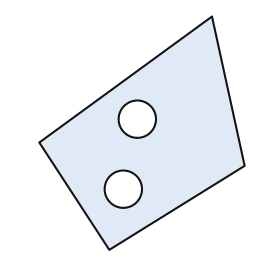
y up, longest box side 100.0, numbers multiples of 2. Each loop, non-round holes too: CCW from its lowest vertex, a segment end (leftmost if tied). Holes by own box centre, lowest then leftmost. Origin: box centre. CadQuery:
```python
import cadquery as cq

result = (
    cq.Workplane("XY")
    .moveTo(-14.0, -50.0)
    .lineTo(44.0, -14.0)
    .lineTo(30.0, 50.0)
    .lineTo(-44.0, -4.0)
    .close()
    .moveTo(-8.0, -24.0)
    .circle(8.0)
    .moveTo(-2.0, 6.0)
    .circle(8.0)
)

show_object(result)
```